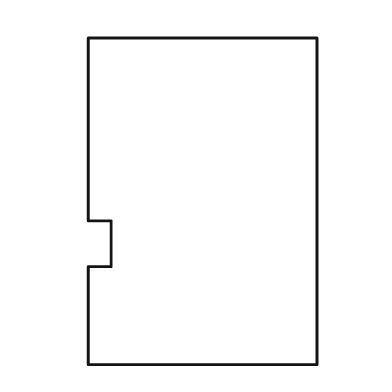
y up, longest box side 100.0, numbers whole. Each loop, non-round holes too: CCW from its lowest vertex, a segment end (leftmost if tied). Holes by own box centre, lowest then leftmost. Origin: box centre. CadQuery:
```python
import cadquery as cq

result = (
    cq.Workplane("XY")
    .moveTo(-35.0, -50.0)
    .lineTo(35.0, -50.0)
    .lineTo(35.0, 50.0)
    .lineTo(-35.0, 50.0)
    .lineTo(-35.0, -6.0)
    .lineTo(-28.0, -6.0)
    .lineTo(-28.0, -20.0)
    .lineTo(-35.0, -20.0)
    .close()
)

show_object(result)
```